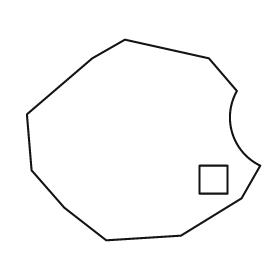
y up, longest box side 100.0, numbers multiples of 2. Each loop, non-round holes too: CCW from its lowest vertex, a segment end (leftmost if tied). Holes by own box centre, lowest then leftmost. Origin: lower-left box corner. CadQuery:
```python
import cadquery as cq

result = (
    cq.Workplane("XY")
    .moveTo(34.0, 0.0)
    .lineTo(66.0, 2.0)
    .lineTo(92.0, 18.0)
    .lineTo(100.0, 32.0)
    .threePointArc((88.0, 46.0), (90.0, 64.0))
    .lineTo(78.0, 78.0)
    .lineTo(42.0, 86.0)
    .lineTo(28.0, 78.0)
    .lineTo(0.0, 54.0)
    .lineTo(2.0, 30.0)
    .lineTo(16.0, 14.0)
    .close()
    .moveTo(74.0, 20.0)
    .lineTo(86.0, 20.0)
    .lineTo(86.0, 32.0)
    .lineTo(74.0, 32.0)
    .close()
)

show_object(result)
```